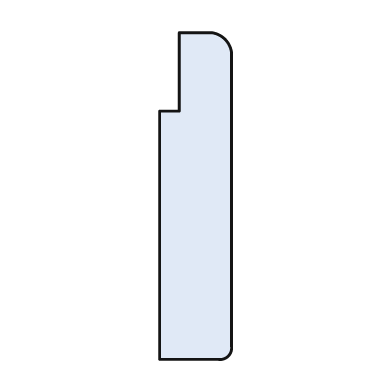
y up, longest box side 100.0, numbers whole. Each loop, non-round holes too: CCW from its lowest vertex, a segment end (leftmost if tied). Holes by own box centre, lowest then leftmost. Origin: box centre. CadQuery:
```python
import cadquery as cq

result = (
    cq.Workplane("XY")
    .moveTo(-11.0, -50.0)
    .lineTo(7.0, -50.0)
    .threePointArc((10.0, -49.0), (11.0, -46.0))
    .lineTo(11.0, 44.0)
    .threePointArc((9.0, 48.0), (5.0, 50.0))
    .lineTo(-5.0, 50.0)
    .lineTo(-5.0, 26.0)
    .lineTo(-11.0, 26.0)
    .close()
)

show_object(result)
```